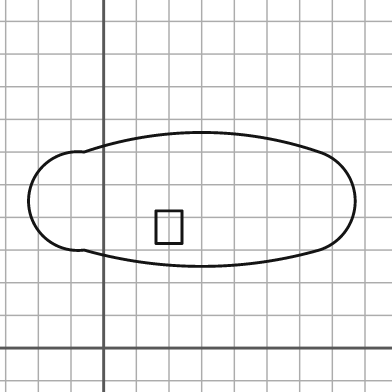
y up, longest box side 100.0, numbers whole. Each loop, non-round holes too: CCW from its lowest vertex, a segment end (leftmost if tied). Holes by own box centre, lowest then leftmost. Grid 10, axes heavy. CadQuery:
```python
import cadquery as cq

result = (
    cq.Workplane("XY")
    .moveTo(-6.0, 30.0)
    .threePointArc((30.0, 25.0), (66.0, 30.0))
    .threePointArc((77.0, 45.0), (66.0, 60.0))
    .threePointArc((30.0, 66.0), (-6.0, 60.0))
    .threePointArc((-23.0, 45.0), (-6.0, 30.0))
    .close()
    .moveTo(16.0, 32.0)
    .lineTo(24.0, 32.0)
    .lineTo(24.0, 42.0)
    .lineTo(16.0, 42.0)
    .close()
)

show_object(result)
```